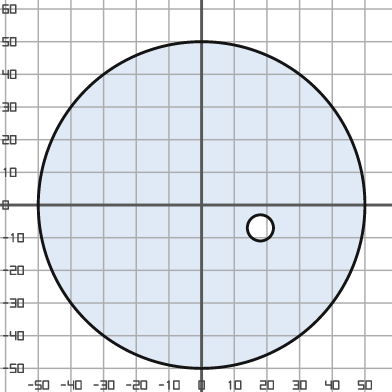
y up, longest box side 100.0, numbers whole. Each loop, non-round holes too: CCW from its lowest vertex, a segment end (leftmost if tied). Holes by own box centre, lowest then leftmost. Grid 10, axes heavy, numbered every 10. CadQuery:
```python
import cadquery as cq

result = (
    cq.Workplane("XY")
    .moveTo(0.0, 0.0)
    .circle(50.0)
    .moveTo(18.0, -7.0)
    .circle(4.0)
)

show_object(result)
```